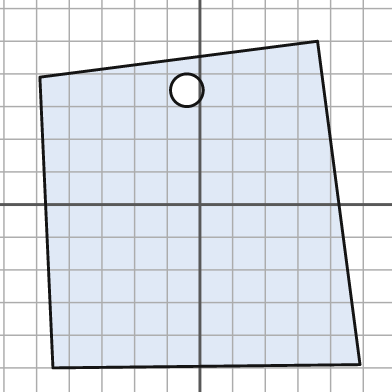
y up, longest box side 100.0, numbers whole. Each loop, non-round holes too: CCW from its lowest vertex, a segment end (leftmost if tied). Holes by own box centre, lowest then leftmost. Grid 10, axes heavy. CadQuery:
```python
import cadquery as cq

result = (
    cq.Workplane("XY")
    .moveTo(-45.0, -50.0)
    .lineTo(49.0, -49.0)
    .lineTo(36.0, 50.0)
    .lineTo(-49.0, 39.0)
    .close()
    .moveTo(-4.0, 35.0)
    .circle(5.0)
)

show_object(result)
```